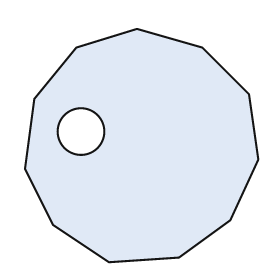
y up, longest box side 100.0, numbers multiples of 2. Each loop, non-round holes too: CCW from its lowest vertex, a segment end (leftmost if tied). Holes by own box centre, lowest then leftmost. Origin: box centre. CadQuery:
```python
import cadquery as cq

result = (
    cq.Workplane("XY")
    .moveTo(-14.0, -50.0)
    .lineTo(16.0, -48.0)
    .lineTo(38.0, -32.0)
    .lineTo(50.0, -6.0)
    .lineTo(46.0, 22.0)
    .lineTo(26.0, 42.0)
    .lineTo(-2.0, 50.0)
    .lineTo(-28.0, 42.0)
    .lineTo(-46.0, 20.0)
    .lineTo(-50.0, -10.0)
    .lineTo(-38.0, -34.0)
    .close()
    .moveTo(-26.0, 6.0)
    .circle(10.0)
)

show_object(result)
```